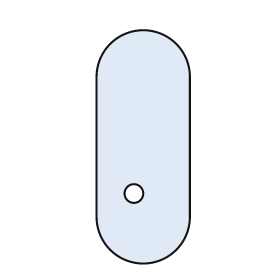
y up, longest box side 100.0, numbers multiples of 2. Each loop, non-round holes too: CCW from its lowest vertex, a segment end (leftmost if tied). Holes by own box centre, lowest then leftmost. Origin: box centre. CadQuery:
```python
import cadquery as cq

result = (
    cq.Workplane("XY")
    .moveTo(-20.0, -30.0)
    .threePointArc((0.0, -50.0), (20.0, -30.0))
    .lineTo(20.0, 30.0)
    .threePointArc((0.0, 50.0), (-20.0, 30.0))
    .close()
    .moveTo(-4.0, -20.0)
    .circle(4.0)
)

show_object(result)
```